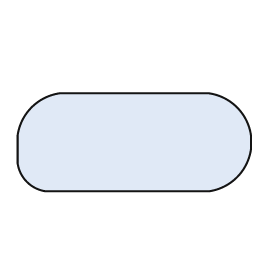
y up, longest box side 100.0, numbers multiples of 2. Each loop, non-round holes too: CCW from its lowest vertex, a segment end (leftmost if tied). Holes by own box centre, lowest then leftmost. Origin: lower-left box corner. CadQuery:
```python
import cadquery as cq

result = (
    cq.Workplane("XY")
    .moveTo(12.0, 0.0)
    .lineTo(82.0, 0.0)
    .threePointArc((94.0, 6.0), (100.0, 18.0))
    .lineTo(100.0, 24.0)
    .threePointArc((94.0, 36.0), (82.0, 42.0))
    .lineTo(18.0, 42.0)
    .threePointArc((6.0, 36.0), (0.0, 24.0))
    .lineTo(0.0, 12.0)
    .threePointArc((4.0, 4.0), (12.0, 0.0))
    .close()
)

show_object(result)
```